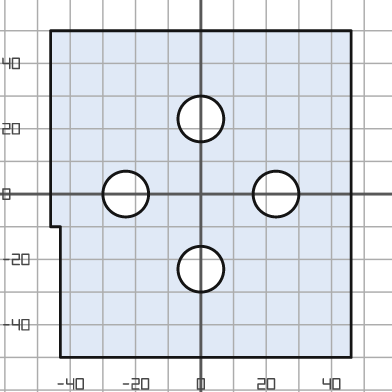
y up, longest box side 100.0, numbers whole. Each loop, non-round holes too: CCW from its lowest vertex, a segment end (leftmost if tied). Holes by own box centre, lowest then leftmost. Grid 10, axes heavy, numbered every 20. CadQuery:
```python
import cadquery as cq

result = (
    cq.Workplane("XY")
    .moveTo(-43.0, -50.0)
    .lineTo(46.0, -50.0)
    .lineTo(46.0, 50.0)
    .lineTo(-46.0, 50.0)
    .lineTo(-46.0, -10.0)
    .lineTo(-43.0, -10.0)
    .close()
    .moveTo(0.0, -23.0)
    .circle(7.0)
    .moveTo(-23.0, 0.0)
    .circle(7.0)
    .moveTo(23.0, 0.0)
    .circle(7.0)
    .moveTo(0.0, 23.0)
    .circle(7.0)
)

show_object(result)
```